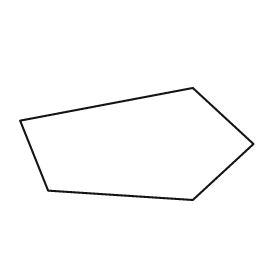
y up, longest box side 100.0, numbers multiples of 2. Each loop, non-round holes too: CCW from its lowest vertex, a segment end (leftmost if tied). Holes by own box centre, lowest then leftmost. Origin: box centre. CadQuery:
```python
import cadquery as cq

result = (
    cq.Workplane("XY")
    .moveTo(24.0, -24.0)
    .lineTo(50.0, 0.0)
    .lineTo(24.0, 24.0)
    .lineTo(-50.0, 10.0)
    .lineTo(-38.0, -20.0)
    .close()
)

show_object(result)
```